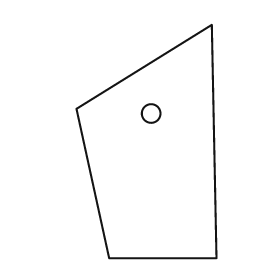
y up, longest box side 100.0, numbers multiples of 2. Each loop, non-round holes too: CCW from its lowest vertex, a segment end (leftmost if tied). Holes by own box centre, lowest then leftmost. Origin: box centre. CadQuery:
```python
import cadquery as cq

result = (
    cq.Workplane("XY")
    .moveTo(-16.0, -50.0)
    .lineTo(30.0, -50.0)
    .lineTo(28.0, 50.0)
    .lineTo(-30.0, 14.0)
    .close()
    .moveTo(2.0, 12.0)
    .circle(4.0)
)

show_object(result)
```